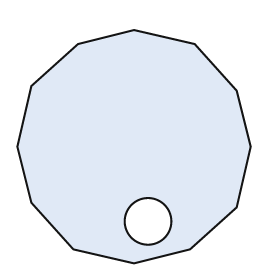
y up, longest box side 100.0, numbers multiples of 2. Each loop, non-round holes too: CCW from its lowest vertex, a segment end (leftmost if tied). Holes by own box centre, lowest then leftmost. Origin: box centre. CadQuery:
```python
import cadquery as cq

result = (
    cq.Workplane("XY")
    .moveTo(0.0, -50.0)
    .lineTo(24.0, -44.0)
    .lineTo(44.0, -26.0)
    .lineTo(50.0, 0.0)
    .lineTo(44.0, 24.0)
    .lineTo(26.0, 44.0)
    .lineTo(0.0, 50.0)
    .lineTo(-24.0, 44.0)
    .lineTo(-44.0, 26.0)
    .lineTo(-50.0, 0.0)
    .lineTo(-44.0, -24.0)
    .lineTo(-26.0, -44.0)
    .close()
    .moveTo(6.0, -32.0)
    .circle(10.0)
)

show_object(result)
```